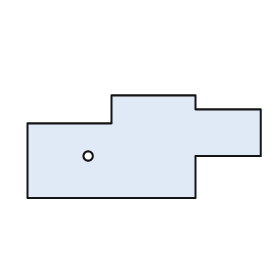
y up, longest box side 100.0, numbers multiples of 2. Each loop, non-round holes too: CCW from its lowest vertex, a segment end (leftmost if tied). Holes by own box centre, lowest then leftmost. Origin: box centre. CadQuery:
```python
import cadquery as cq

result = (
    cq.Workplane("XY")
    .moveTo(-50.0, -22.0)
    .lineTo(22.0, -22.0)
    .lineTo(22.0, -4.0)
    .lineTo(50.0, -4.0)
    .lineTo(50.0, 16.0)
    .lineTo(22.0, 16.0)
    .lineTo(22.0, 22.0)
    .lineTo(-14.0, 22.0)
    .lineTo(-14.0, 10.0)
    .lineTo(-50.0, 10.0)
    .close()
    .moveTo(-24.0, -4.0)
    .circle(2.0)
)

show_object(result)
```